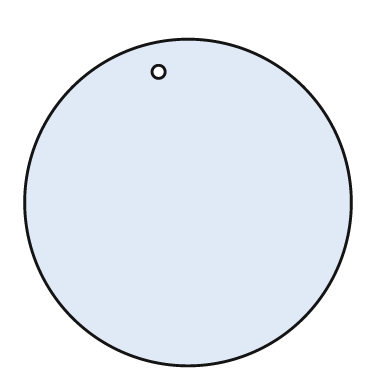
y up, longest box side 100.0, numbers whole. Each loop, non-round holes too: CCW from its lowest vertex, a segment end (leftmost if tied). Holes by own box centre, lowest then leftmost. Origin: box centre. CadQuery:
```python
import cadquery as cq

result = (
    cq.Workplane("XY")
    .moveTo(0.0, 0.0)
    .circle(50.0)
    .moveTo(-9.0, 40.0)
    .circle(2.0)
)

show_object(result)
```